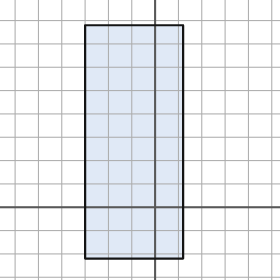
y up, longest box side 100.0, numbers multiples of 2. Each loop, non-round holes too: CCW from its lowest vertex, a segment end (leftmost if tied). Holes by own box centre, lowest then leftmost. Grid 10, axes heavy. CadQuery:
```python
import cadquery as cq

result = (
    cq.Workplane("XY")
    .moveTo(-30.0, -22.0)
    .lineTo(12.0, -22.0)
    .lineTo(12.0, 78.0)
    .lineTo(-30.0, 78.0)
    .close()
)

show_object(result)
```